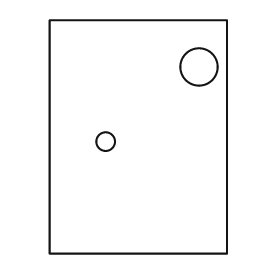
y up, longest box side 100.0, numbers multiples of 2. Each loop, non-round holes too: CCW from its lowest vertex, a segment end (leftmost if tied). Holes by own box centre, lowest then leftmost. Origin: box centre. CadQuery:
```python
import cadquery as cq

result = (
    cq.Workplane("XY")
    .moveTo(-38.0, -50.0)
    .lineTo(38.0, -50.0)
    .lineTo(38.0, 50.0)
    .lineTo(-38.0, 50.0)
    .close()
    .moveTo(-14.0, -2.0)
    .circle(4.0)
    .moveTo(26.0, 30.0)
    .circle(8.0)
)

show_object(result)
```